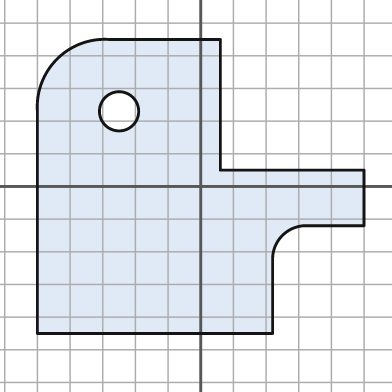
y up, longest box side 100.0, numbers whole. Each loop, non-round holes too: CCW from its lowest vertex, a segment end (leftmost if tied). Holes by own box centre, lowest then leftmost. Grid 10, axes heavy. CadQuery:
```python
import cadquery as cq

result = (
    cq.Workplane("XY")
    .moveTo(-50.0, -45.0)
    .lineTo(22.0, -45.0)
    .lineTo(22.0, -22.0)
    .threePointArc((25.0, -15.0), (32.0, -12.0))
    .lineTo(50.0, -12.0)
    .lineTo(50.0, 5.0)
    .lineTo(6.0, 5.0)
    .lineTo(6.0, 45.0)
    .lineTo(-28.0, 45.0)
    .threePointArc((-44.0, 39.0), (-50.0, 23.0))
    .close()
    .moveTo(-25.0, 23.0)
    .circle(6.0)
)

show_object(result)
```